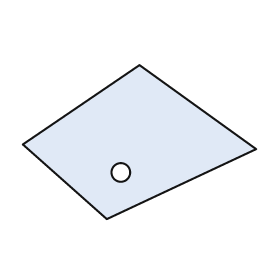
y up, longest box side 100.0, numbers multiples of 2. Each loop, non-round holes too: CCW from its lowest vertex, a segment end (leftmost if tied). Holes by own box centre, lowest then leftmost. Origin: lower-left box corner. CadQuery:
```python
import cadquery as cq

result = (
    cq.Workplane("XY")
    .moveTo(36.0, 0.0)
    .lineTo(100.0, 30.0)
    .lineTo(50.0, 66.0)
    .lineTo(0.0, 32.0)
    .close()
    .moveTo(42.0, 20.0)
    .circle(4.0)
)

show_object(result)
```